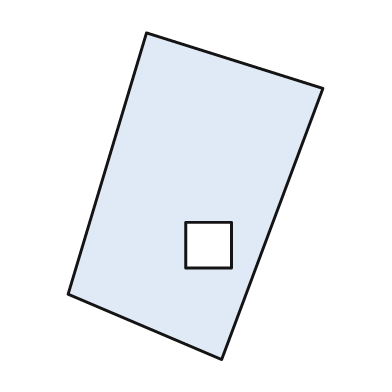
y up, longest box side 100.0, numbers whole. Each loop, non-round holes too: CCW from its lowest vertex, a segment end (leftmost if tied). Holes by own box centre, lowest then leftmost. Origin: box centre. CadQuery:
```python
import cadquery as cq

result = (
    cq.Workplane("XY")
    .moveTo(8.0, -50.0)
    .lineTo(39.0, 33.0)
    .lineTo(-15.0, 50.0)
    .lineTo(-39.0, -30.0)
    .close()
    .moveTo(-3.0, -22.0)
    .lineTo(11.0, -22.0)
    .lineTo(11.0, -8.0)
    .lineTo(-3.0, -8.0)
    .close()
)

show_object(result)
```